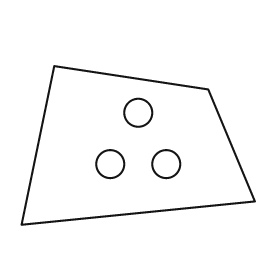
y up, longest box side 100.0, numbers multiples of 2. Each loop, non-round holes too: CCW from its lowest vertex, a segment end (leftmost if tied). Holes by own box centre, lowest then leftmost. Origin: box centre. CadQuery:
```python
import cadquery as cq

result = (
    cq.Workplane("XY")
    .moveTo(-50.0, -34.0)
    .lineTo(50.0, -24.0)
    .lineTo(30.0, 24.0)
    .lineTo(-36.0, 34.0)
    .close()
    .moveTo(-12.0, -8.0)
    .circle(6.0)
    .moveTo(12.0, -8.0)
    .circle(6.0)
    .moveTo(0.0, 14.0)
    .circle(6.0)
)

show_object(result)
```